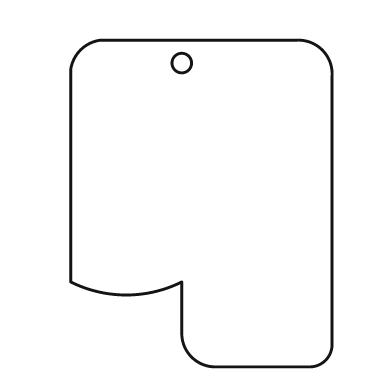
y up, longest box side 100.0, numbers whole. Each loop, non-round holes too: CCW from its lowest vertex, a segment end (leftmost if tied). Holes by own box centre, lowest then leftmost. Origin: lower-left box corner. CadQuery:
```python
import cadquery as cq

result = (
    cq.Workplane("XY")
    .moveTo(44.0, 0.0)
    .lineTo(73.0, 0.0)
    .threePointArc((78.0, 2.0), (80.0, 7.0))
    .lineTo(80.0, 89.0)
    .threePointArc((77.0, 97.0), (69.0, 100.0))
    .lineTo(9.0, 100.0)
    .threePointArc((3.0, 97.0), (0.0, 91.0))
    .lineTo(0.0, 26.0)
    .threePointArc((17.0, 22.0), (34.0, 26.0))
    .lineTo(34.0, 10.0)
    .threePointArc((37.0, 3.0), (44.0, 0.0))
    .close()
    .moveTo(34.0, 93.0)
    .circle(3.0)
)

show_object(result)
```